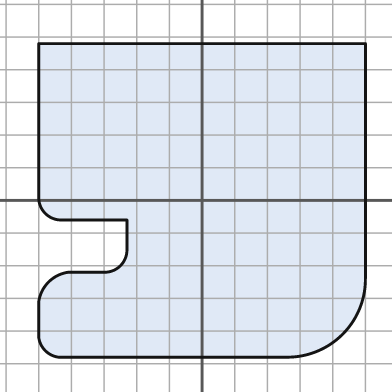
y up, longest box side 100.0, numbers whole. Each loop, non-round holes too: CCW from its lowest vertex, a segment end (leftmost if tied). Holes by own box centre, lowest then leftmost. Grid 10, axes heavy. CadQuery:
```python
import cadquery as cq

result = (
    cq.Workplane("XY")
    .moveTo(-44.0, -48.0)
    .lineTo(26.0, -48.0)
    .threePointArc((43.0, -41.0), (50.0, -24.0))
    .lineTo(50.0, 48.0)
    .lineTo(-50.0, 48.0)
    .lineTo(-50.0, 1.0)
    .threePointArc((-48.0, -4.0), (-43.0, -6.0))
    .lineTo(-23.0, -6.0)
    .lineTo(-23.0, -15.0)
    .threePointArc((-25.0, -20.0), (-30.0, -22.0))
    .lineTo(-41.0, -22.0)
    .threePointArc((-47.0, -25.0), (-50.0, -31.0))
    .lineTo(-50.0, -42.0)
    .threePointArc((-48.0, -46.0), (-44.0, -48.0))
    .close()
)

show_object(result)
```